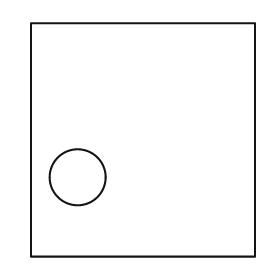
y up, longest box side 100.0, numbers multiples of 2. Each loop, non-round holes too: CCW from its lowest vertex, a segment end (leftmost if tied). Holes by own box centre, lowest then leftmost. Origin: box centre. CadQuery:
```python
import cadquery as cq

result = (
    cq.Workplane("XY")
    .moveTo(-48.0, -50.0)
    .lineTo(48.0, -50.0)
    .lineTo(48.0, 50.0)
    .lineTo(-48.0, 50.0)
    .close()
    .moveTo(-28.0, -16.0)
    .circle(12.0)
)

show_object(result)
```